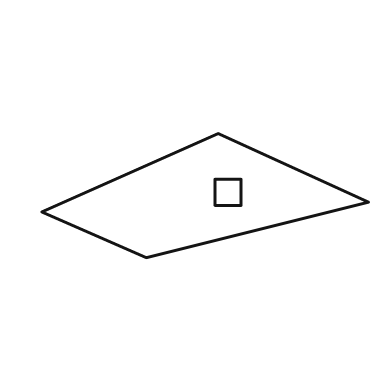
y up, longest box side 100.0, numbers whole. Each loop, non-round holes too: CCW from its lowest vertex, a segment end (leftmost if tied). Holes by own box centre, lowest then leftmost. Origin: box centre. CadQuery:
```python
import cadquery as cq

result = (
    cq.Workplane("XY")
    .moveTo(-18.0, -19.0)
    .lineTo(50.0, -2.0)
    .lineTo(4.0, 19.0)
    .lineTo(-50.0, -5.0)
    .close()
    .moveTo(3.0, -3.0)
    .lineTo(11.0, -3.0)
    .lineTo(11.0, 5.0)
    .lineTo(3.0, 5.0)
    .close()
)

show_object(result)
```